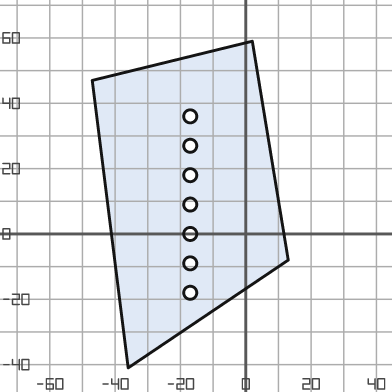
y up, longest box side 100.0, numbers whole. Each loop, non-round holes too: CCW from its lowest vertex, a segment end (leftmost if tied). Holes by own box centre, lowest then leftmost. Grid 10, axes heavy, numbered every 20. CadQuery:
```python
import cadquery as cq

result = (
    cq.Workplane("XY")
    .moveTo(-36.0, -41.0)
    .lineTo(13.0, -8.0)
    .lineTo(2.0, 59.0)
    .lineTo(-47.0, 47.0)
    .close()
    .moveTo(-17.0, -18.0)
    .circle(2.0)
    .moveTo(-17.0, -9.0)
    .circle(2.0)
    .moveTo(-17.0, 0.0)
    .circle(2.0)
    .moveTo(-17.0, 9.0)
    .circle(2.0)
    .moveTo(-17.0, 18.0)
    .circle(2.0)
    .moveTo(-17.0, 27.0)
    .circle(2.0)
    .moveTo(-17.0, 36.0)
    .circle(2.0)
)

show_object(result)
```